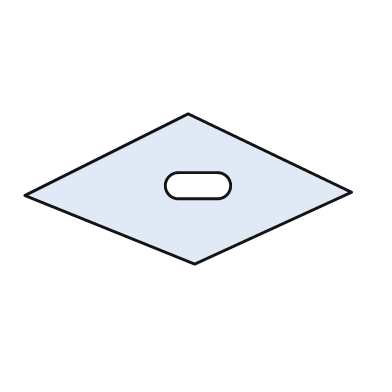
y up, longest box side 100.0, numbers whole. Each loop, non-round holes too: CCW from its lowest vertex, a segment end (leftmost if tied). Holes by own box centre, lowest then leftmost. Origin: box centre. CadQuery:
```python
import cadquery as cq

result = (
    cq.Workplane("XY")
    .moveTo(2.0, -23.0)
    .lineTo(50.0, -1.0)
    .lineTo(0.0, 23.0)
    .lineTo(-50.0, -2.0)
    .close()
    .moveTo(-3.0, -3.0)
    .lineTo(9.0, -3.0)
    .threePointArc((13.0, 1.0), (9.0, 5.0))
    .lineTo(-3.0, 5.0)
    .threePointArc((-7.0, 1.0), (-3.0, -3.0))
    .close()
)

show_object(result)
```